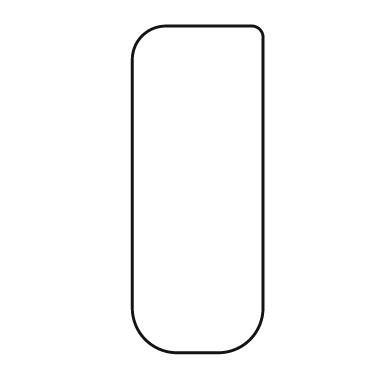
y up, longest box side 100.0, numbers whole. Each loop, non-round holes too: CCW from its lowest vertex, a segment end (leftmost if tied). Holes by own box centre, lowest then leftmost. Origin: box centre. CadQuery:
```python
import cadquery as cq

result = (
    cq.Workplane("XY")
    .moveTo(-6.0, -50.0)
    .lineTo(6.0, -50.0)
    .threePointArc((16.0, -46.0), (20.0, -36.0))
    .lineTo(20.0, 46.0)
    .threePointArc((19.0, 49.0), (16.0, 50.0))
    .lineTo(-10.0, 50.0)
    .threePointArc((-17.0, 47.0), (-20.0, 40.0))
    .lineTo(-20.0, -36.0)
    .threePointArc((-16.0, -46.0), (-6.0, -50.0))
    .close()
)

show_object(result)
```